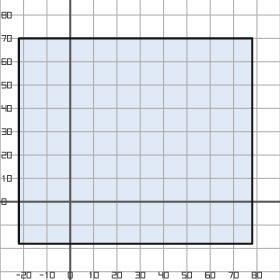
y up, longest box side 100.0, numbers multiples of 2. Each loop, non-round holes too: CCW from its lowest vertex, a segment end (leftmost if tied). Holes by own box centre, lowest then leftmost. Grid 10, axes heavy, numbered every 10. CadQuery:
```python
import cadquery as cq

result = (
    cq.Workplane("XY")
    .moveTo(-22.0, -18.0)
    .lineTo(78.0, -18.0)
    .lineTo(78.0, 70.0)
    .lineTo(-22.0, 70.0)
    .close()
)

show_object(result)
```